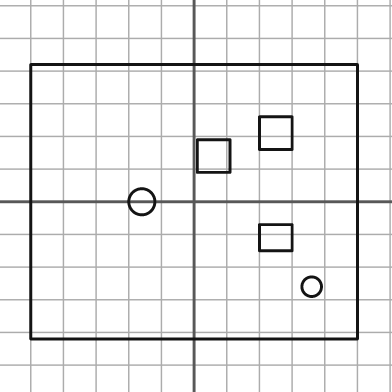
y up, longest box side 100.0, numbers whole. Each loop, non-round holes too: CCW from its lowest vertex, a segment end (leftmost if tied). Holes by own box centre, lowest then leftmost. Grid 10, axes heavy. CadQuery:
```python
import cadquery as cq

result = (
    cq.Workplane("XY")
    .moveTo(-50.0, -42.0)
    .lineTo(50.0, -42.0)
    .lineTo(50.0, 42.0)
    .lineTo(-50.0, 42.0)
    .close()
    .moveTo(36.0, -26.0)
    .circle(3.0)
    .moveTo(20.0, -15.0)
    .lineTo(30.0, -15.0)
    .lineTo(30.0, -7.0)
    .lineTo(20.0, -7.0)
    .close()
    .moveTo(-16.0, 0.0)
    .circle(4.0)
    .moveTo(1.0, 9.0)
    .lineTo(11.0, 9.0)
    .lineTo(11.0, 19.0)
    .lineTo(1.0, 19.0)
    .close()
    .moveTo(20.0, 16.0)
    .lineTo(30.0, 16.0)
    .lineTo(30.0, 26.0)
    .lineTo(20.0, 26.0)
    .close()
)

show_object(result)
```